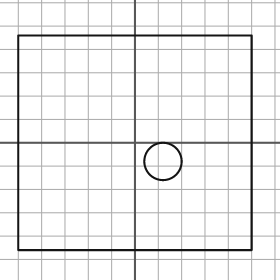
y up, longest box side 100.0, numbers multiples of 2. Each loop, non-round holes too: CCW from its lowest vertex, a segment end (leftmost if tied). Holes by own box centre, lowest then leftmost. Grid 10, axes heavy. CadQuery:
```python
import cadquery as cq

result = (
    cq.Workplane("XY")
    .moveTo(-50.0, -46.0)
    .lineTo(50.0, -46.0)
    .lineTo(50.0, 46.0)
    .lineTo(-50.0, 46.0)
    .close()
    .moveTo(12.0, -8.0)
    .circle(8.0)
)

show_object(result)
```